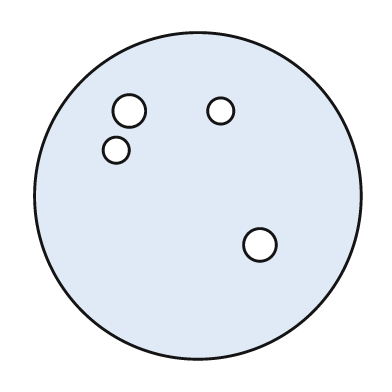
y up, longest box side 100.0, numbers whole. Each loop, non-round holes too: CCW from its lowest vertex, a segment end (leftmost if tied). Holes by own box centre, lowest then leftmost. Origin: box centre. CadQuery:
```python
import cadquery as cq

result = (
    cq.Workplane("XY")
    .moveTo(0.0, 0.0)
    .circle(50.0)
    .moveTo(19.0, -15.0)
    .circle(5.0)
    .moveTo(-25.0, 14.0)
    .circle(4.0)
    .moveTo(-21.0, 26.0)
    .circle(5.0)
    .moveTo(7.0, 26.0)
    .circle(4.0)
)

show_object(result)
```